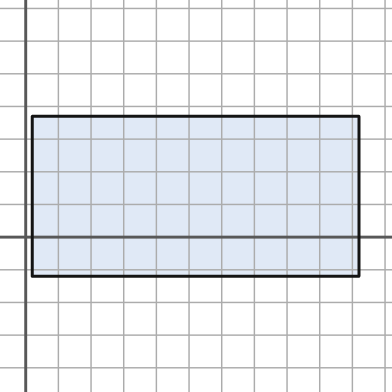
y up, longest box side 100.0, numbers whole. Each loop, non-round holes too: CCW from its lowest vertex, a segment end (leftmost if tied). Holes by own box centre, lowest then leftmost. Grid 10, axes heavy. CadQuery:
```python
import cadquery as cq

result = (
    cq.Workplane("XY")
    .moveTo(2.0, -12.0)
    .lineTo(102.0, -12.0)
    .lineTo(102.0, 37.0)
    .lineTo(2.0, 37.0)
    .close()
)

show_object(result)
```